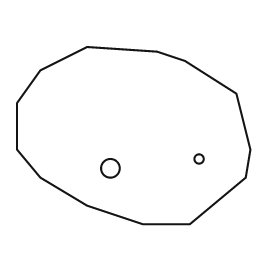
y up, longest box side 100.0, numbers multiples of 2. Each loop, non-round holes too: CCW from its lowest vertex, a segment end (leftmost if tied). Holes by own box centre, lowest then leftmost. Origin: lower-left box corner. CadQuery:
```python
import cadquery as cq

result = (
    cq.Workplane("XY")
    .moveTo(54.0, 0.0)
    .lineTo(74.0, 0.0)
    .lineTo(98.0, 20.0)
    .lineTo(100.0, 32.0)
    .lineTo(94.0, 56.0)
    .lineTo(72.0, 70.0)
    .lineTo(60.0, 74.0)
    .lineTo(30.0, 76.0)
    .lineTo(10.0, 66.0)
    .lineTo(0.0, 52.0)
    .lineTo(0.0, 32.0)
    .lineTo(10.0, 20.0)
    .lineTo(30.0, 8.0)
    .close()
    .moveTo(40.0, 24.0)
    .circle(4.0)
    .moveTo(78.0, 28.0)
    .circle(2.0)
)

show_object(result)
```